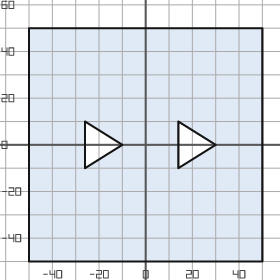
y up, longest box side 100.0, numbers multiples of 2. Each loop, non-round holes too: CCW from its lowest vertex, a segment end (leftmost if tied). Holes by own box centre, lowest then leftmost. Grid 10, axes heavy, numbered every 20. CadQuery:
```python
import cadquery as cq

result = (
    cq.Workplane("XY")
    .moveTo(-50.0, -50.0)
    .lineTo(50.0, -50.0)
    .lineTo(50.0, 50.0)
    .lineTo(-50.0, 50.0)
    .close()
    .moveTo(-26.0, -10.0)
    .lineTo(-10.0, 0.0)
    .lineTo(-26.0, 10.0)
    .close()
    .moveTo(14.0, -10.0)
    .lineTo(30.0, 0.0)
    .lineTo(14.0, 10.0)
    .close()
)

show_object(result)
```